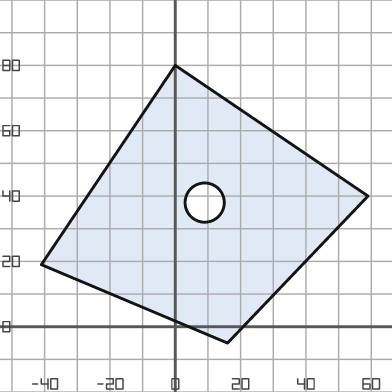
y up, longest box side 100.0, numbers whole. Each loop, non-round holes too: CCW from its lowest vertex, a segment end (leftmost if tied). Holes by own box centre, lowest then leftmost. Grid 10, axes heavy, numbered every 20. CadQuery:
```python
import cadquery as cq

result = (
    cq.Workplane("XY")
    .moveTo(16.0, -5.0)
    .lineTo(59.0, 40.0)
    .lineTo(0.0, 80.0)
    .lineTo(-41.0, 19.0)
    .close()
    .moveTo(9.0, 38.0)
    .circle(6.0)
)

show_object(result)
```